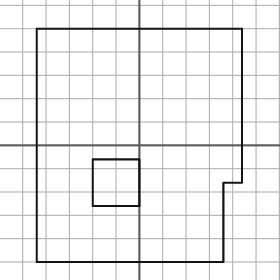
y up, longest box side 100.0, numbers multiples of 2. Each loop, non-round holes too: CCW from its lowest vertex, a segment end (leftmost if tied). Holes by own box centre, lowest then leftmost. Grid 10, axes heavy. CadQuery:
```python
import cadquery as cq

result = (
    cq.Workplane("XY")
    .moveTo(-44.0, -50.0)
    .lineTo(36.0, -50.0)
    .lineTo(36.0, -16.0)
    .lineTo(44.0, -16.0)
    .lineTo(44.0, 50.0)
    .lineTo(-44.0, 50.0)
    .close()
    .moveTo(-20.0, -26.0)
    .lineTo(0.0, -26.0)
    .lineTo(0.0, -6.0)
    .lineTo(-20.0, -6.0)
    .close()
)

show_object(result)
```